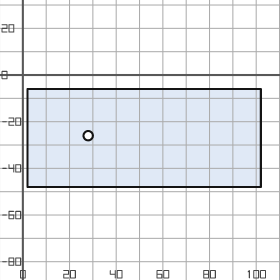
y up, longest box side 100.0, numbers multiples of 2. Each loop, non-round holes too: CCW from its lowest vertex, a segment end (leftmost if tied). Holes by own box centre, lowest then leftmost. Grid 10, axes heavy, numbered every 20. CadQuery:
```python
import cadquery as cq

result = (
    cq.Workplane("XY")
    .moveTo(2.0, -48.0)
    .lineTo(102.0, -48.0)
    .lineTo(102.0, -6.0)
    .lineTo(2.0, -6.0)
    .close()
    .moveTo(28.0, -26.0)
    .circle(2.0)
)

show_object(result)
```